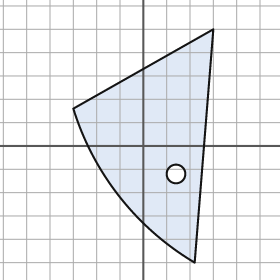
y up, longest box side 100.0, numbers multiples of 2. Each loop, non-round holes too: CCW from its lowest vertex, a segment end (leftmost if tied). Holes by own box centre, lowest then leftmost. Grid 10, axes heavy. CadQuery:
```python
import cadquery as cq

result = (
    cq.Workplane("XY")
    .moveTo(22.0, -50.0)
    .lineTo(30.0, 50.0)
    .lineTo(-30.0, 16.0)
    .threePointArc((-10.0, -22.0), (22.0, -50.0))
    .close()
    .moveTo(14.0, -12.0)
    .circle(4.0)
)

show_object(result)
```